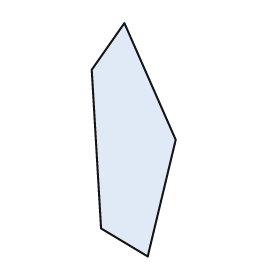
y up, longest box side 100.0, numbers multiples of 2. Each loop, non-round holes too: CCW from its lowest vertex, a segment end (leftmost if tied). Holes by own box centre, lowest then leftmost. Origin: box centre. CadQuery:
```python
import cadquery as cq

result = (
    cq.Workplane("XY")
    .moveTo(6.0, -50.0)
    .lineTo(18.0, 0.0)
    .lineTo(-4.0, 50.0)
    .lineTo(-18.0, 30.0)
    .lineTo(-14.0, -38.0)
    .close()
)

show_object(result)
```